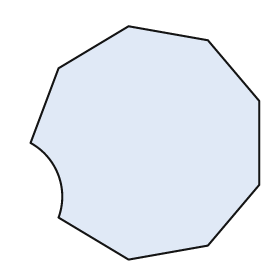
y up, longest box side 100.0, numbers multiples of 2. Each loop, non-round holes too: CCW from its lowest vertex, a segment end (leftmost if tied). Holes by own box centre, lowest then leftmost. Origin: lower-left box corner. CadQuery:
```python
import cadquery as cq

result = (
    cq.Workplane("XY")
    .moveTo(42.0, 0.0)
    .lineTo(76.0, 6.0)
    .lineTo(98.0, 32.0)
    .lineTo(98.0, 68.0)
    .lineTo(76.0, 94.0)
    .lineTo(42.0, 100.0)
    .lineTo(12.0, 82.0)
    .lineTo(0.0, 50.0)
    .threePointArc((12.0, 36.0), (12.0, 18.0))
    .close()
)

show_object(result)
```